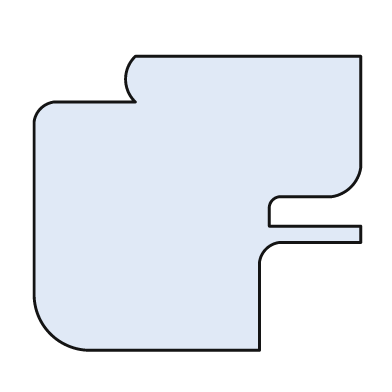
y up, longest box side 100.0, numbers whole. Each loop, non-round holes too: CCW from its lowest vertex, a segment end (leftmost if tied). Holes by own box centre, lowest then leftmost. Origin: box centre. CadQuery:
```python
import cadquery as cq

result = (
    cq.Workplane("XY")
    .moveTo(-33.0, -45.0)
    .lineTo(19.0, -45.0)
    .lineTo(19.0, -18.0)
    .threePointArc((21.0, -14.0), (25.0, -12.0))
    .lineTo(50.0, -12.0)
    .lineTo(50.0, -7.0)
    .lineTo(22.0, -7.0)
    .lineTo(22.0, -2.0)
    .threePointArc((23.0, 1.0), (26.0, 2.0))
    .lineTo(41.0, 2.0)
    .threePointArc((47.0, 5.0), (50.0, 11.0))
    .lineTo(50.0, 45.0)
    .lineTo(-19.0, 45.0)
    .threePointArc((-22.0, 38.0), (-19.0, 31.0))
    .lineTo(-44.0, 31.0)
    .threePointArc((-48.0, 29.0), (-50.0, 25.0))
    .lineTo(-50.0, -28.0)
    .threePointArc((-45.0, -40.0), (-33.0, -45.0))
    .close()
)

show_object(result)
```